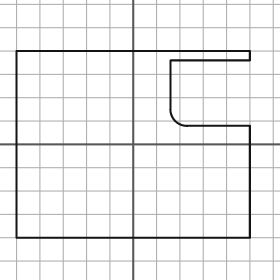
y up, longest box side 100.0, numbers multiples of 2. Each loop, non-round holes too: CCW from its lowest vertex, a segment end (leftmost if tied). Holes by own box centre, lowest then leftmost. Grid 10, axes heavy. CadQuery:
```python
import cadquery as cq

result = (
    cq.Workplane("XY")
    .moveTo(-50.0, -40.0)
    .lineTo(50.0, -40.0)
    .lineTo(50.0, 8.0)
    .lineTo(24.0, 8.0)
    .threePointArc((18.0, 10.0), (16.0, 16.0))
    .lineTo(16.0, 36.0)
    .lineTo(50.0, 36.0)
    .lineTo(50.0, 40.0)
    .lineTo(-50.0, 40.0)
    .close()
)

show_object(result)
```